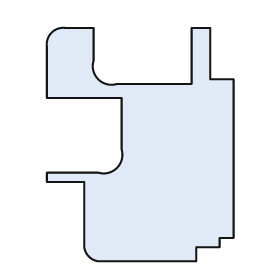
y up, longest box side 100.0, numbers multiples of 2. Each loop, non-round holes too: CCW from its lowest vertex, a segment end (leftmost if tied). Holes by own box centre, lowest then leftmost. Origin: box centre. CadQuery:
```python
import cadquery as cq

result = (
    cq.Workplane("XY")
    .moveTo(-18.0, -50.0)
    .lineTo(24.0, -50.0)
    .lineTo(24.0, -44.0)
    .lineTo(34.0, -44.0)
    .lineTo(34.0, -40.0)
    .lineTo(40.0, -40.0)
    .lineTo(40.0, 28.0)
    .lineTo(30.0, 28.0)
    .lineTo(30.0, 50.0)
    .lineTo(22.0, 50.0)
    .lineTo(22.0, 26.0)
    .lineTo(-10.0, 26.0)
    .threePointArc((-18.0, 28.0), (-20.0, 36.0))
    .lineTo(-20.0, 50.0)
    .lineTo(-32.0, 50.0)
    .threePointArc((-38.0, 48.0), (-40.0, 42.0))
    .lineTo(-40.0, 20.0)
    .lineTo(-8.0, 20.0)
    .lineTo(-8.0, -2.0)
    .threePointArc((-10.0, -10.0), (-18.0, -12.0))
    .lineTo(-40.0, -12.0)
    .lineTo(-40.0, -16.0)
    .lineTo(-24.0, -16.0)
    .lineTo(-24.0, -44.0)
    .threePointArc((-22.0, -48.0), (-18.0, -50.0))
    .close()
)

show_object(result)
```